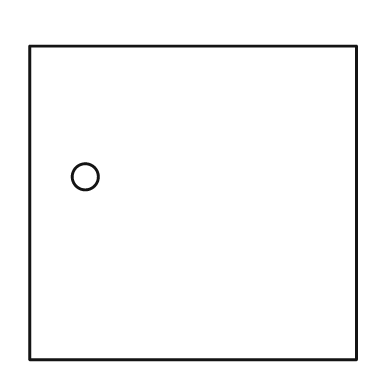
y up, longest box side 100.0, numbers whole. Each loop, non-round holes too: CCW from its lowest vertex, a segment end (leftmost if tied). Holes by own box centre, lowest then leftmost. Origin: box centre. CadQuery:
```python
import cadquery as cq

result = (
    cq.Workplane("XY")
    .moveTo(-50.0, -48.0)
    .lineTo(50.0, -48.0)
    .lineTo(50.0, 48.0)
    .lineTo(-50.0, 48.0)
    .close()
    .moveTo(-33.0, 8.0)
    .circle(4.0)
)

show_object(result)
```